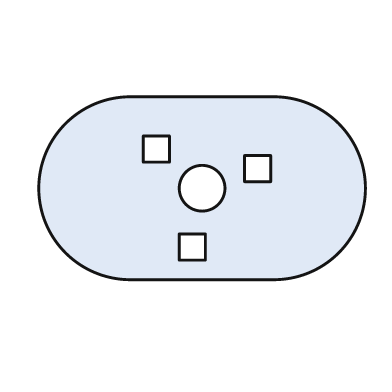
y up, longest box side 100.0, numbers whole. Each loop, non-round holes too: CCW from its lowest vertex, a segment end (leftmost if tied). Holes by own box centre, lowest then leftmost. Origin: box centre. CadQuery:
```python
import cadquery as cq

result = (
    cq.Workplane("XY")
    .moveTo(-22.0, -28.0)
    .lineTo(22.0, -28.0)
    .threePointArc((50.0, 0.0), (22.0, 28.0))
    .lineTo(-22.0, 28.0)
    .threePointArc((-50.0, 0.0), (-22.0, -28.0))
    .close()
    .moveTo(-7.0, -22.0)
    .lineTo(1.0, -22.0)
    .lineTo(1.0, -14.0)
    .lineTo(-7.0, -14.0)
    .close()
    .moveTo(0.0, 0.0)
    .circle(7.0)
    .moveTo(13.0, 2.0)
    .lineTo(21.0, 2.0)
    .lineTo(21.0, 10.0)
    .lineTo(13.0, 10.0)
    .close()
    .moveTo(-18.0, 8.0)
    .lineTo(-10.0, 8.0)
    .lineTo(-10.0, 16.0)
    .lineTo(-18.0, 16.0)
    .close()
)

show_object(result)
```